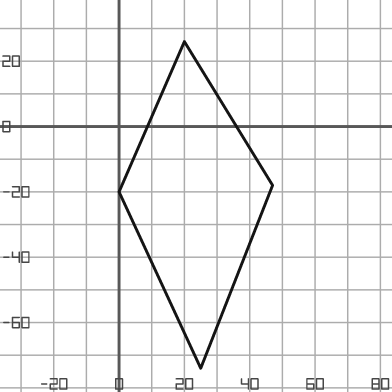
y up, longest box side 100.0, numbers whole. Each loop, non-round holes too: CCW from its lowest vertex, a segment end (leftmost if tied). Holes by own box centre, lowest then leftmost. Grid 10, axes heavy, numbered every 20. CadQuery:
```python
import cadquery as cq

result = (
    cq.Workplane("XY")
    .moveTo(25.0, -74.0)
    .lineTo(47.0, -18.0)
    .lineTo(20.0, 26.0)
    .lineTo(0.0, -20.0)
    .close()
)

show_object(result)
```